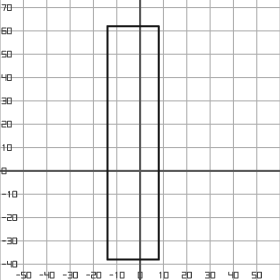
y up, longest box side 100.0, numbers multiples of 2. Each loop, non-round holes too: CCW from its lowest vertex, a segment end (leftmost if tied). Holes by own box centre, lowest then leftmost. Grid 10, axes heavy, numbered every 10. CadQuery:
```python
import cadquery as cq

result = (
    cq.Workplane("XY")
    .moveTo(-14.0, -38.0)
    .lineTo(8.0, -38.0)
    .lineTo(8.0, 62.0)
    .lineTo(-14.0, 62.0)
    .close()
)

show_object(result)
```